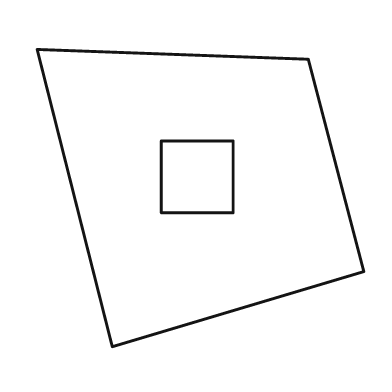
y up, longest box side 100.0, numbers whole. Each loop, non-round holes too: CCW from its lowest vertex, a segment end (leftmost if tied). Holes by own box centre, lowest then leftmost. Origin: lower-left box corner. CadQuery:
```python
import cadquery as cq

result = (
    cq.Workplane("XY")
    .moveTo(23.0, 0.0)
    .lineTo(100.0, 23.0)
    .lineTo(83.0, 88.0)
    .lineTo(0.0, 91.0)
    .close()
    .moveTo(38.0, 41.0)
    .lineTo(60.0, 41.0)
    .lineTo(60.0, 63.0)
    .lineTo(38.0, 63.0)
    .close()
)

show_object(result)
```